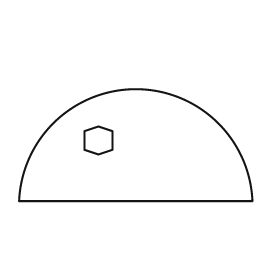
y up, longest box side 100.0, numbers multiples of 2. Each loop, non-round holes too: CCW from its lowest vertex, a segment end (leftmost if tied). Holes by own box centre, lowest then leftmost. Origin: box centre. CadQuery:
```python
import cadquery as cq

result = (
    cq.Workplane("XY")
    .moveTo(-50.0, -24.0)
    .lineTo(50.0, -24.0)
    .threePointArc((0.0, 24.0), (-50.0, -24.0))
    .close()
    .moveTo(-16.0, -4.0)
    .lineTo(-10.0, -2.0)
    .lineTo(-10.0, 6.0)
    .lineTo(-16.0, 8.0)
    .lineTo(-22.0, 6.0)
    .lineTo(-22.0, -2.0)
    .close()
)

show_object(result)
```